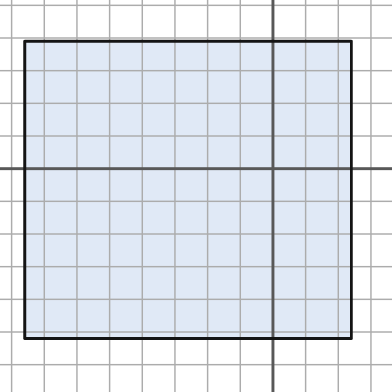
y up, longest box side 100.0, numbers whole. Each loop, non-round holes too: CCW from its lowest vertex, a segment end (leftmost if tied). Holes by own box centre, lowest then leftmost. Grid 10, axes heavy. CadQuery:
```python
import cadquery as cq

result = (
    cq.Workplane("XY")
    .moveTo(-76.0, -52.0)
    .lineTo(24.0, -52.0)
    .lineTo(24.0, 39.0)
    .lineTo(-76.0, 39.0)
    .close()
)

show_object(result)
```